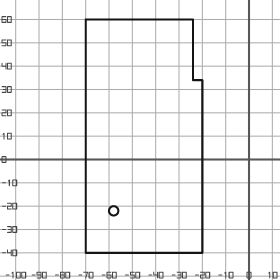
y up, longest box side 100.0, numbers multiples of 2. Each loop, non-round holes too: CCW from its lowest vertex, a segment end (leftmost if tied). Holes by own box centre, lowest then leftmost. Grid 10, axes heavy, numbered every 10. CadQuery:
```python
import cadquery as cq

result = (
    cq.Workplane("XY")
    .moveTo(-70.0, -40.0)
    .lineTo(-20.0, -40.0)
    .lineTo(-20.0, 34.0)
    .lineTo(-24.0, 34.0)
    .lineTo(-24.0, 60.0)
    .lineTo(-70.0, 60.0)
    .close()
    .moveTo(-58.0, -22.0)
    .circle(2.0)
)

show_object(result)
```